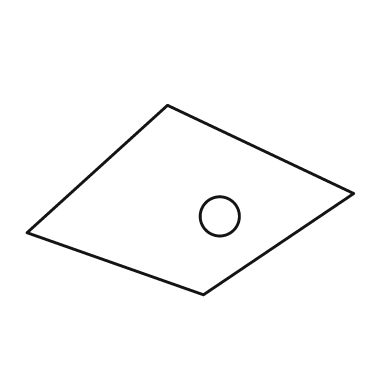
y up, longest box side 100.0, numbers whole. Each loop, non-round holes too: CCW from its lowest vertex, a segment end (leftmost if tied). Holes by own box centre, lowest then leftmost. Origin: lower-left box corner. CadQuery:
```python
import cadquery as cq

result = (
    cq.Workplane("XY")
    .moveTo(54.0, 0.0)
    .lineTo(100.0, 31.0)
    .lineTo(43.0, 58.0)
    .lineTo(0.0, 19.0)
    .close()
    .moveTo(59.0, 24.0)
    .circle(6.0)
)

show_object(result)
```